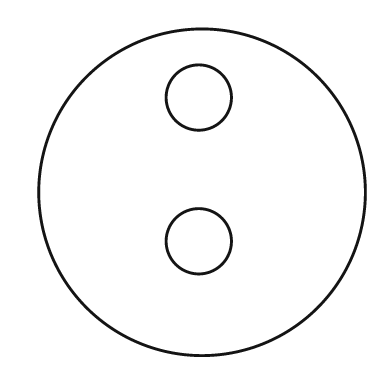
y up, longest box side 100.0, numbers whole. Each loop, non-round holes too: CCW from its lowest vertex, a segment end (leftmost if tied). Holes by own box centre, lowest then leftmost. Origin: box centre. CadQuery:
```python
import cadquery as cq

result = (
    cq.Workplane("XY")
    .moveTo(0.0, 0.0)
    .circle(50.0)
    .moveTo(-1.0, -15.0)
    .circle(10.0)
    .moveTo(-1.0, 29.0)
    .circle(10.0)
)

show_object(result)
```